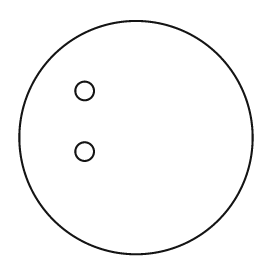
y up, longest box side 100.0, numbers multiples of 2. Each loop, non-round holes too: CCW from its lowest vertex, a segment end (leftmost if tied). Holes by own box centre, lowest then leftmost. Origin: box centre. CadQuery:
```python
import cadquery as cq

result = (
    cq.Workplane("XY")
    .moveTo(0.0, 0.0)
    .circle(50.0)
    .moveTo(-22.0, -6.0)
    .circle(4.0)
    .moveTo(-22.0, 20.0)
    .circle(4.0)
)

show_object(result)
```